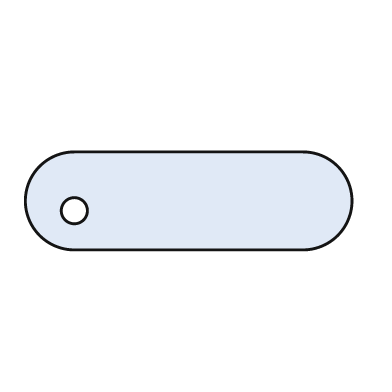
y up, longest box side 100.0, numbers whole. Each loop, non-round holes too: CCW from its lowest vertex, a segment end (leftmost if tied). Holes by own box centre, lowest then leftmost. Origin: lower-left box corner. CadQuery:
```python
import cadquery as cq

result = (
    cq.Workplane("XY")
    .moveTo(15.0, 0.0)
    .lineTo(85.0, 0.0)
    .threePointArc((100.0, 15.0), (85.0, 30.0))
    .lineTo(15.0, 30.0)
    .threePointArc((0.0, 15.0), (15.0, 0.0))
    .close()
    .moveTo(15.0, 12.0)
    .circle(4.0)
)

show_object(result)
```